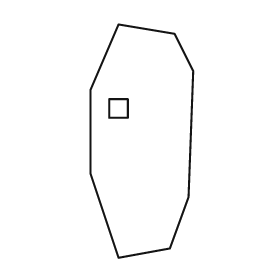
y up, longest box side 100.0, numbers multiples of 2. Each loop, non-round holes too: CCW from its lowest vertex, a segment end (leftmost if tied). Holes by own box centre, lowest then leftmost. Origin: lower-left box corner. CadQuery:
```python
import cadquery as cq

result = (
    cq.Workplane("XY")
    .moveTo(12.0, 0.0)
    .lineTo(34.0, 4.0)
    .lineTo(42.0, 26.0)
    .lineTo(44.0, 80.0)
    .lineTo(36.0, 96.0)
    .lineTo(12.0, 100.0)
    .lineTo(0.0, 72.0)
    .lineTo(0.0, 36.0)
    .close()
    .moveTo(8.0, 60.0)
    .lineTo(16.0, 60.0)
    .lineTo(16.0, 68.0)
    .lineTo(8.0, 68.0)
    .close()
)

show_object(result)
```